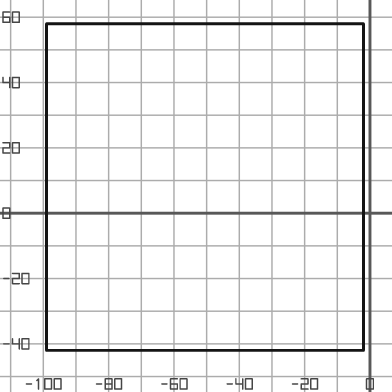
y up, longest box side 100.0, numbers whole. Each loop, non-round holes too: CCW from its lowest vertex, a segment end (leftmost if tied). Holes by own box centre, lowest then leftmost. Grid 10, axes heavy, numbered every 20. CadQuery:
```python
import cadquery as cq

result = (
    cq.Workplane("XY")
    .moveTo(-99.0, -42.0)
    .lineTo(-2.0, -42.0)
    .lineTo(-2.0, 58.0)
    .lineTo(-99.0, 58.0)
    .close()
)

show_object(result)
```